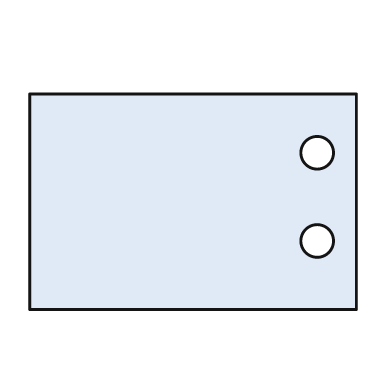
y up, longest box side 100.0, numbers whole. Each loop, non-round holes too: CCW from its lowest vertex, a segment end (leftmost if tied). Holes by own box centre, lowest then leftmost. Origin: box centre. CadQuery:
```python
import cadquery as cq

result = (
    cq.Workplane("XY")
    .moveTo(-50.0, -33.0)
    .lineTo(50.0, -33.0)
    .lineTo(50.0, 33.0)
    .lineTo(-50.0, 33.0)
    .close()
    .moveTo(38.0, -12.0)
    .circle(5.0)
    .moveTo(38.0, 15.0)
    .circle(5.0)
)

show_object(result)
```